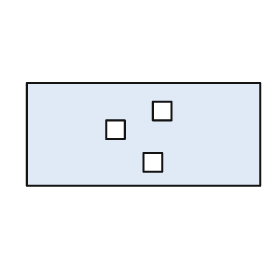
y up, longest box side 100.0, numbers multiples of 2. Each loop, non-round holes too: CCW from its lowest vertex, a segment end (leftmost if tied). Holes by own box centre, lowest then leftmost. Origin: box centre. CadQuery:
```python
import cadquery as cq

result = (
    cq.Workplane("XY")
    .moveTo(-50.0, -22.0)
    .lineTo(50.0, -22.0)
    .lineTo(50.0, 22.0)
    .lineTo(-50.0, 22.0)
    .close()
    .moveTo(0.0, -16.0)
    .lineTo(8.0, -16.0)
    .lineTo(8.0, -8.0)
    .lineTo(0.0, -8.0)
    .close()
    .moveTo(-16.0, -2.0)
    .lineTo(-8.0, -2.0)
    .lineTo(-8.0, 6.0)
    .lineTo(-16.0, 6.0)
    .close()
    .moveTo(4.0, 6.0)
    .lineTo(12.0, 6.0)
    .lineTo(12.0, 14.0)
    .lineTo(4.0, 14.0)
    .close()
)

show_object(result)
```